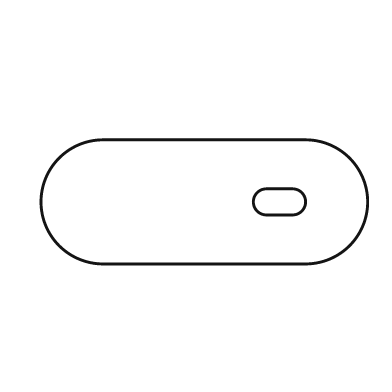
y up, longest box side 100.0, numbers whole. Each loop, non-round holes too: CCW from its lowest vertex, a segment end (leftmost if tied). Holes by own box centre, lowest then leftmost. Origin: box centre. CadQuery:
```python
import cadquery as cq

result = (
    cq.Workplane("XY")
    .moveTo(-31.0, -19.0)
    .lineTo(31.0, -19.0)
    .threePointArc((50.0, 0.0), (31.0, 19.0))
    .lineTo(-31.0, 19.0)
    .threePointArc((-50.0, 0.0), (-31.0, -19.0))
    .close()
    .moveTo(19.0, -4.0)
    .lineTo(27.0, -4.0)
    .threePointArc((31.0, 0.0), (27.0, 4.0))
    .lineTo(19.0, 4.0)
    .threePointArc((15.0, 0.0), (19.0, -4.0))
    .close()
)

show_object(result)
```